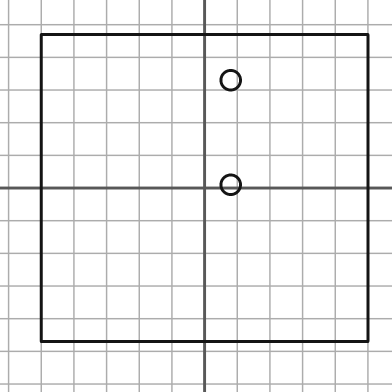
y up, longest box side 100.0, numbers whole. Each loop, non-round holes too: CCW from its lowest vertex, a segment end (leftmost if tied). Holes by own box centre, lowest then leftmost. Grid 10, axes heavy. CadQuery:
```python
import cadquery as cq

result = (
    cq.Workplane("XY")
    .moveTo(-50.0, -47.0)
    .lineTo(50.0, -47.0)
    .lineTo(50.0, 47.0)
    .lineTo(-50.0, 47.0)
    .close()
    .moveTo(8.0, 1.0)
    .circle(3.0)
    .moveTo(8.0, 33.0)
    .circle(3.0)
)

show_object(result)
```